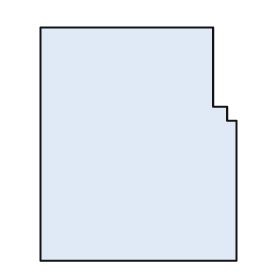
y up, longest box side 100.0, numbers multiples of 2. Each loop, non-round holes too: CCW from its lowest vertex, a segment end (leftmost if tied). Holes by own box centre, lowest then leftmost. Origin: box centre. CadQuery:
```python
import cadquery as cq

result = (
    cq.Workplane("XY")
    .moveTo(-42.0, -50.0)
    .lineTo(42.0, -50.0)
    .lineTo(42.0, 10.0)
    .lineTo(38.0, 10.0)
    .lineTo(38.0, 16.0)
    .lineTo(32.0, 16.0)
    .lineTo(32.0, 50.0)
    .lineTo(-42.0, 50.0)
    .close()
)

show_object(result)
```